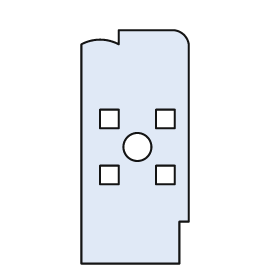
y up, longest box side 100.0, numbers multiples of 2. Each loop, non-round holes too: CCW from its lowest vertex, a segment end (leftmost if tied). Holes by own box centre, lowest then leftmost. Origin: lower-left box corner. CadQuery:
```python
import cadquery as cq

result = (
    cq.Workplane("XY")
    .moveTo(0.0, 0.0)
    .lineTo(42.0, 0.0)
    .lineTo(42.0, 18.0)
    .lineTo(46.0, 18.0)
    .lineTo(46.0, 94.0)
    .threePointArc((44.0, 98.0), (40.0, 100.0))
    .lineTo(16.0, 100.0)
    .lineTo(16.0, 94.0)
    .threePointArc((8.0, 96.0), (0.0, 94.0))
    .close()
    .moveTo(8.0, 34.0)
    .lineTo(16.0, 34.0)
    .lineTo(16.0, 42.0)
    .lineTo(8.0, 42.0)
    .close()
    .moveTo(32.0, 34.0)
    .lineTo(40.0, 34.0)
    .lineTo(40.0, 42.0)
    .lineTo(32.0, 42.0)
    .close()
    .moveTo(24.0, 50.0)
    .circle(6.0)
    .moveTo(8.0, 58.0)
    .lineTo(16.0, 58.0)
    .lineTo(16.0, 66.0)
    .lineTo(8.0, 66.0)
    .close()
    .moveTo(32.0, 58.0)
    .lineTo(40.0, 58.0)
    .lineTo(40.0, 66.0)
    .lineTo(32.0, 66.0)
    .close()
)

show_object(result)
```